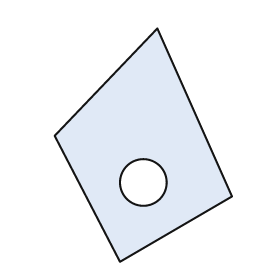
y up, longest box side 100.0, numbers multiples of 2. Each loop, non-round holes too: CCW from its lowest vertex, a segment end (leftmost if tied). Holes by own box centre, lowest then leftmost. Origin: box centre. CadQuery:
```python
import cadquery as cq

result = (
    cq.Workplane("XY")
    .moveTo(-10.0, -50.0)
    .lineTo(38.0, -22.0)
    .lineTo(6.0, 50.0)
    .lineTo(-38.0, 4.0)
    .close()
    .moveTo(0.0, -16.0)
    .circle(10.0)
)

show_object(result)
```